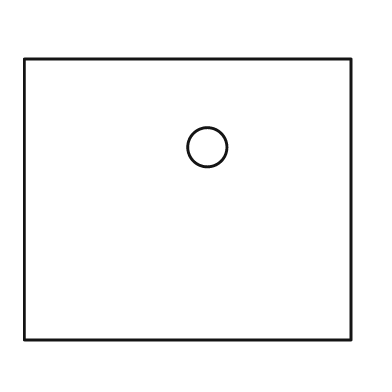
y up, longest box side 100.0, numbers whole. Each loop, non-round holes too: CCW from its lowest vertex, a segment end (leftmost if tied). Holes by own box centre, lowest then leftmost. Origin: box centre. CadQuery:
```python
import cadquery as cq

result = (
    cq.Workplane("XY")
    .moveTo(-50.0, -43.0)
    .lineTo(50.0, -43.0)
    .lineTo(50.0, 43.0)
    .lineTo(-50.0, 43.0)
    .close()
    .moveTo(6.0, 16.0)
    .circle(6.0)
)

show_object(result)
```